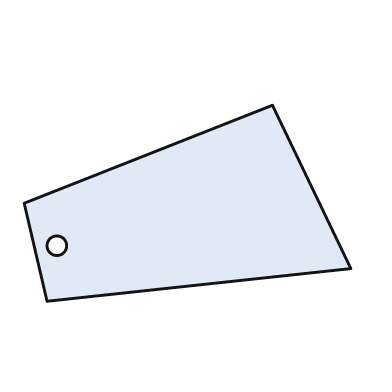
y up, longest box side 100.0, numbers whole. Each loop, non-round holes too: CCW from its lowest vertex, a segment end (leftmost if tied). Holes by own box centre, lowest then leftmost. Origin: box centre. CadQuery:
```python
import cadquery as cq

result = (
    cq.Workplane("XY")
    .moveTo(-43.0, -30.0)
    .lineTo(50.0, -20.0)
    .lineTo(26.0, 30.0)
    .lineTo(-50.0, 0.0)
    .close()
    .moveTo(-40.0, -13.0)
    .circle(3.0)
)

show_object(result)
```